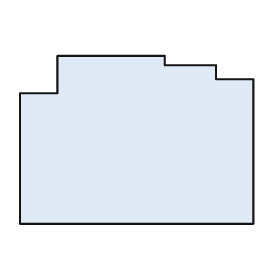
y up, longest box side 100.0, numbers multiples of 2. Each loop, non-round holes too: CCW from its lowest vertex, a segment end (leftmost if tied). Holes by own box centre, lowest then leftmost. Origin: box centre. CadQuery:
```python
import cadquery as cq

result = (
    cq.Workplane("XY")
    .moveTo(-50.0, -36.0)
    .lineTo(50.0, -36.0)
    .lineTo(50.0, 26.0)
    .lineTo(34.0, 26.0)
    .lineTo(34.0, 32.0)
    .lineTo(12.0, 32.0)
    .lineTo(12.0, 36.0)
    .lineTo(-34.0, 36.0)
    .lineTo(-34.0, 20.0)
    .lineTo(-50.0, 20.0)
    .close()
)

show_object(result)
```